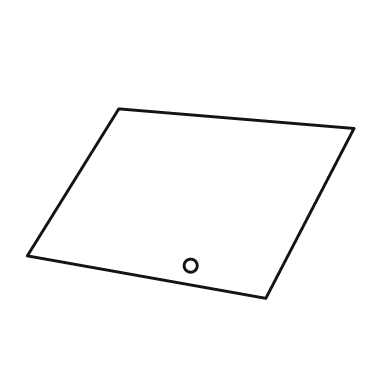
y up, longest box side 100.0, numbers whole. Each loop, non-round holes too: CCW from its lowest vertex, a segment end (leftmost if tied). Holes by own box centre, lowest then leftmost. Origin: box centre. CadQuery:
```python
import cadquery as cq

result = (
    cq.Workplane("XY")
    .moveTo(23.0, -29.0)
    .lineTo(50.0, 23.0)
    .lineTo(-22.0, 29.0)
    .lineTo(-50.0, -16.0)
    .close()
    .moveTo(0.0, -19.0)
    .circle(2.0)
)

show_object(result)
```